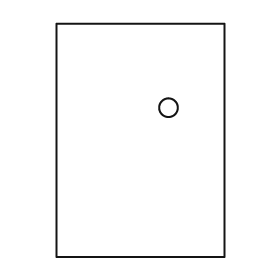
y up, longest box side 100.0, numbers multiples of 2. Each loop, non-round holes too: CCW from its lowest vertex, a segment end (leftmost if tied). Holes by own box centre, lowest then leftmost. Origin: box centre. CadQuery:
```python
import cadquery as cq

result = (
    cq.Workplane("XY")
    .moveTo(-36.0, -50.0)
    .lineTo(36.0, -50.0)
    .lineTo(36.0, 50.0)
    .lineTo(-36.0, 50.0)
    .close()
    .moveTo(12.0, 14.0)
    .circle(4.0)
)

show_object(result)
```